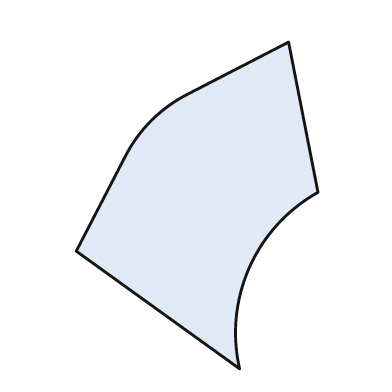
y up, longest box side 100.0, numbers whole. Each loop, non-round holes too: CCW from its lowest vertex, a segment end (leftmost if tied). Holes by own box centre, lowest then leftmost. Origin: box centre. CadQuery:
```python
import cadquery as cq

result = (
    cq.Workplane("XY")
    .moveTo(13.0, -50.0)
    .threePointArc((16.0, -19.0), (37.0, 4.0))
    .lineTo(28.0, 50.0)
    .lineTo(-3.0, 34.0)
    .threePointArc((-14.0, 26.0), (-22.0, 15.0))
    .lineTo(-37.0, -14.0)
    .close()
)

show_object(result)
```